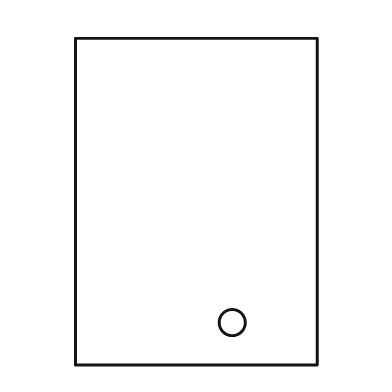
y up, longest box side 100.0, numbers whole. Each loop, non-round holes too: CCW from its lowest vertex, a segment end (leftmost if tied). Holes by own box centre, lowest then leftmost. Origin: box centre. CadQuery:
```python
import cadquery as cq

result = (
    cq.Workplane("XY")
    .moveTo(-37.0, -50.0)
    .lineTo(37.0, -50.0)
    .lineTo(37.0, 50.0)
    .lineTo(-37.0, 50.0)
    .close()
    .moveTo(11.0, -37.0)
    .circle(4.0)
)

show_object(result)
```